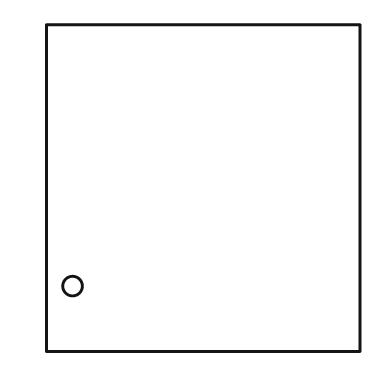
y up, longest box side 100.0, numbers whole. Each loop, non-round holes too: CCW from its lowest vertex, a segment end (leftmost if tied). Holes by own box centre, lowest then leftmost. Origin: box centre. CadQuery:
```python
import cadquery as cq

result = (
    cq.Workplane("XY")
    .moveTo(-48.0, -50.0)
    .lineTo(48.0, -50.0)
    .lineTo(48.0, 50.0)
    .lineTo(-48.0, 50.0)
    .close()
    .moveTo(-40.0, -30.0)
    .circle(3.0)
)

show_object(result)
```